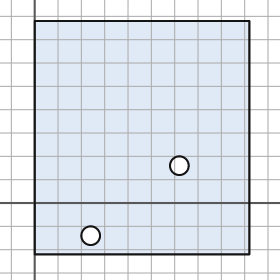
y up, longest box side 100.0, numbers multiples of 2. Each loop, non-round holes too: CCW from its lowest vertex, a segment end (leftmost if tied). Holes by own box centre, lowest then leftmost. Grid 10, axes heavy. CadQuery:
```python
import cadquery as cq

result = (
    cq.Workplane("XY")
    .moveTo(0.0, -22.0)
    .lineTo(92.0, -22.0)
    .lineTo(92.0, 78.0)
    .lineTo(0.0, 78.0)
    .close()
    .moveTo(24.0, -14.0)
    .circle(4.0)
    .moveTo(62.0, 16.0)
    .circle(4.0)
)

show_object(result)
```